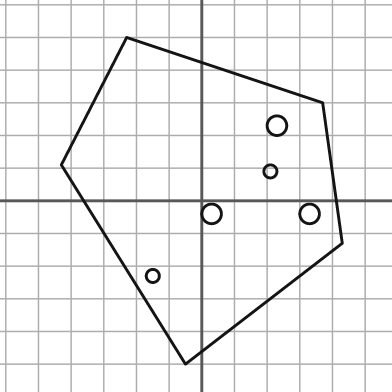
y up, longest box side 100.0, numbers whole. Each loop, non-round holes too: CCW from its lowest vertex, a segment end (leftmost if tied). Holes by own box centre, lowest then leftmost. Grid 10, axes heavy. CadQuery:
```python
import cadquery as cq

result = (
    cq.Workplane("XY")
    .moveTo(-5.0, -50.0)
    .lineTo(43.0, -13.0)
    .lineTo(37.0, 30.0)
    .lineTo(-23.0, 50.0)
    .lineTo(-43.0, 11.0)
    .close()
    .moveTo(-15.0, -23.0)
    .circle(2.0)
    .moveTo(3.0, -4.0)
    .circle(3.0)
    .moveTo(33.0, -4.0)
    .circle(3.0)
    .moveTo(21.0, 9.0)
    .circle(2.0)
    .moveTo(23.0, 23.0)
    .circle(3.0)
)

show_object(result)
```